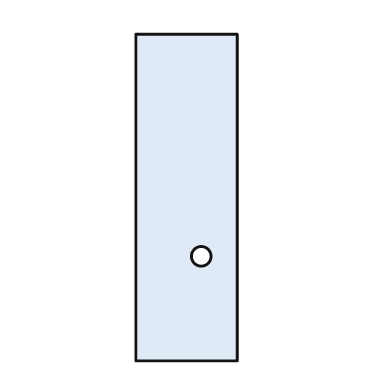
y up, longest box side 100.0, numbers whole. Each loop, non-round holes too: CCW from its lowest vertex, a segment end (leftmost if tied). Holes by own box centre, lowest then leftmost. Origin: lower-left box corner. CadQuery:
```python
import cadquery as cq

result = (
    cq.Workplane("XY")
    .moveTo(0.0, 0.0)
    .lineTo(31.0, 0.0)
    .lineTo(31.0, 100.0)
    .lineTo(0.0, 100.0)
    .close()
    .moveTo(20.0, 32.0)
    .circle(3.0)
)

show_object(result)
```